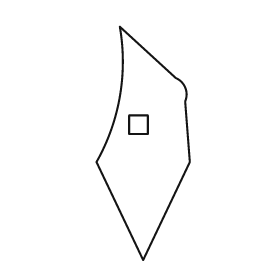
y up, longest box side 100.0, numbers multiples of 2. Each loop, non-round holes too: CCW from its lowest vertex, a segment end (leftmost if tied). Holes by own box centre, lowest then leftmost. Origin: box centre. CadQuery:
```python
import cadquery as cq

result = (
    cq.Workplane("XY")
    .moveTo(0.0, -50.0)
    .lineTo(20.0, -8.0)
    .lineTo(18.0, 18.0)
    .threePointArc((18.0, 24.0), (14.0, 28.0))
    .lineTo(-10.0, 50.0)
    .threePointArc((-10.0, 20.0), (-20.0, -8.0))
    .close()
    .moveTo(-6.0, 4.0)
    .lineTo(2.0, 4.0)
    .lineTo(2.0, 12.0)
    .lineTo(-6.0, 12.0)
    .close()
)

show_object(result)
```